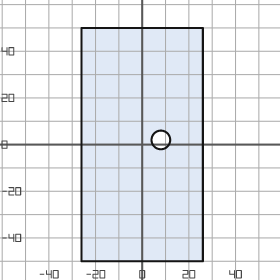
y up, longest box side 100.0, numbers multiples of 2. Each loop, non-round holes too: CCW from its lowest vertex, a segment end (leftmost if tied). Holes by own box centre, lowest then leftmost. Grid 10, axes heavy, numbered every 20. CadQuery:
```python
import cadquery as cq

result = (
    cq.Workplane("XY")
    .moveTo(-26.0, -50.0)
    .lineTo(26.0, -50.0)
    .lineTo(26.0, 50.0)
    .lineTo(-26.0, 50.0)
    .close()
    .moveTo(8.0, 2.0)
    .circle(4.0)
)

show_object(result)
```